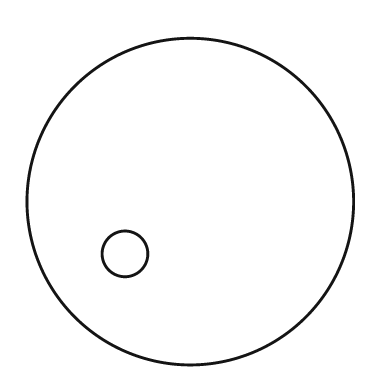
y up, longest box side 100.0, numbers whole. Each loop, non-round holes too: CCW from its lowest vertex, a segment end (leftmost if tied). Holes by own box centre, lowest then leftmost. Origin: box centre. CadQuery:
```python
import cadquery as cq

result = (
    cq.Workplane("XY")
    .moveTo(0.0, 0.0)
    .circle(50.0)
    .moveTo(-20.0, -16.0)
    .circle(7.0)
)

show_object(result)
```